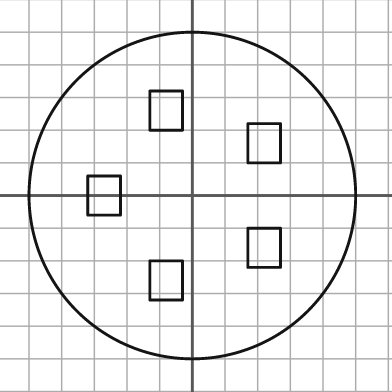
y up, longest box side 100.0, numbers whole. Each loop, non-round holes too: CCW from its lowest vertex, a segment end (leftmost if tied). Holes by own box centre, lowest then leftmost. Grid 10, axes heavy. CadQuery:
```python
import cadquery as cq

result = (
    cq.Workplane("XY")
    .moveTo(0.0, 0.0)
    .circle(50.0)
    .moveTo(-13.0, -32.0)
    .lineTo(-3.0, -32.0)
    .lineTo(-3.0, -20.0)
    .lineTo(-13.0, -20.0)
    .close()
    .moveTo(17.0, -22.0)
    .lineTo(27.0, -22.0)
    .lineTo(27.0, -10.0)
    .lineTo(17.0, -10.0)
    .close()
    .moveTo(-32.0, -6.0)
    .lineTo(-22.0, -6.0)
    .lineTo(-22.0, 6.0)
    .lineTo(-32.0, 6.0)
    .close()
    .moveTo(17.0, 10.0)
    .lineTo(27.0, 10.0)
    .lineTo(27.0, 22.0)
    .lineTo(17.0, 22.0)
    .close()
    .moveTo(-13.0, 20.0)
    .lineTo(-3.0, 20.0)
    .lineTo(-3.0, 32.0)
    .lineTo(-13.0, 32.0)
    .close()
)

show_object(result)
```